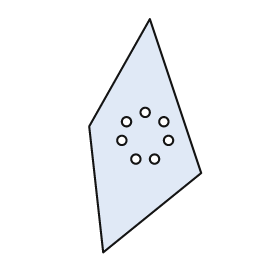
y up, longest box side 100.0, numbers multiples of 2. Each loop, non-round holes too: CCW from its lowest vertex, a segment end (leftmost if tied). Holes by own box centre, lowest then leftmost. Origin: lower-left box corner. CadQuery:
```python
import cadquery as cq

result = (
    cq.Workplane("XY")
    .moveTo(6.0, 0.0)
    .lineTo(48.0, 34.0)
    .lineTo(26.0, 100.0)
    .lineTo(0.0, 54.0)
    .close()
    .moveTo(20.0, 40.0)
    .circle(2.0)
    .moveTo(28.0, 40.0)
    .circle(2.0)
    .moveTo(14.0, 48.0)
    .circle(2.0)
    .moveTo(34.0, 48.0)
    .circle(2.0)
    .moveTo(16.0, 56.0)
    .circle(2.0)
    .moveTo(32.0, 56.0)
    .circle(2.0)
    .moveTo(24.0, 60.0)
    .circle(2.0)
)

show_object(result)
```